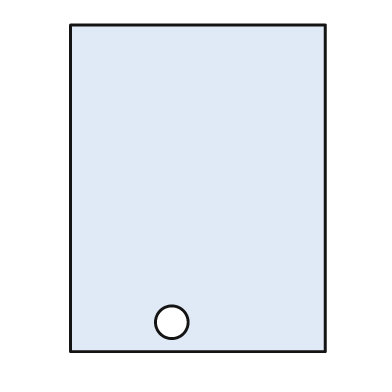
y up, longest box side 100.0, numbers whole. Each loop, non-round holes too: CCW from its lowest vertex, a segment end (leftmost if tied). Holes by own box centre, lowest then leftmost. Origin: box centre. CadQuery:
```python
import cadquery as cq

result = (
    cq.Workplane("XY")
    .moveTo(-39.0, -50.0)
    .lineTo(39.0, -50.0)
    .lineTo(39.0, 50.0)
    .lineTo(-39.0, 50.0)
    .close()
    .moveTo(-8.0, -41.0)
    .circle(5.0)
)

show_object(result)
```